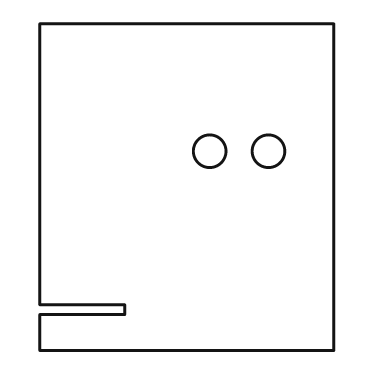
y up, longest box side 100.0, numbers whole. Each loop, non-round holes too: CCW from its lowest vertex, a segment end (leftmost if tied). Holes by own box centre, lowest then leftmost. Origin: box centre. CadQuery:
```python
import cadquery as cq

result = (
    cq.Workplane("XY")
    .moveTo(-45.0, -50.0)
    .lineTo(45.0, -50.0)
    .lineTo(45.0, 50.0)
    .lineTo(-45.0, 50.0)
    .lineTo(-45.0, -36.0)
    .lineTo(-19.0, -36.0)
    .lineTo(-19.0, -39.0)
    .lineTo(-45.0, -39.0)
    .close()
    .moveTo(7.0, 11.0)
    .circle(5.0)
    .moveTo(25.0, 11.0)
    .circle(5.0)
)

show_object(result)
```